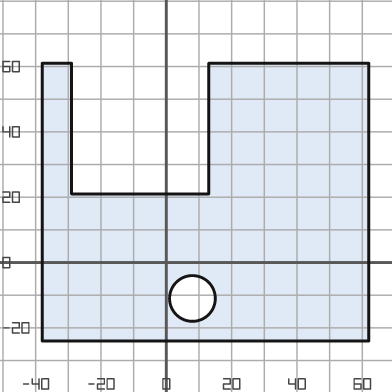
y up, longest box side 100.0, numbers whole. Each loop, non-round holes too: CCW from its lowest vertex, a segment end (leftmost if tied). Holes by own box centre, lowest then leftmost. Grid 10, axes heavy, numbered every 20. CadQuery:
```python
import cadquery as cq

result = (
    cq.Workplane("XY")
    .moveTo(-38.0, -24.0)
    .lineTo(62.0, -24.0)
    .lineTo(62.0, 61.0)
    .lineTo(13.0, 61.0)
    .lineTo(13.0, 21.0)
    .lineTo(-29.0, 21.0)
    .lineTo(-29.0, 61.0)
    .lineTo(-38.0, 61.0)
    .close()
    .moveTo(8.0, -11.0)
    .circle(7.0)
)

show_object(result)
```